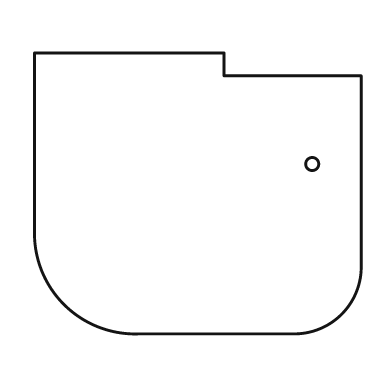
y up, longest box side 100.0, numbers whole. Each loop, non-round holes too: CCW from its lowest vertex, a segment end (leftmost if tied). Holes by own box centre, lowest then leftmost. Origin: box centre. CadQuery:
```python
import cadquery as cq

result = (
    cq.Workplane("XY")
    .moveTo(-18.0, -43.0)
    .lineTo(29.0, -43.0)
    .threePointArc((44.0, -37.0), (50.0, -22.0))
    .lineTo(50.0, 36.0)
    .lineTo(8.0, 36.0)
    .lineTo(8.0, 43.0)
    .lineTo(-50.0, 43.0)
    .lineTo(-50.0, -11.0)
    .threePointArc((-41.0, -34.0), (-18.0, -43.0))
    .close()
    .moveTo(35.0, 9.0)
    .circle(2.0)
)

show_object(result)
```